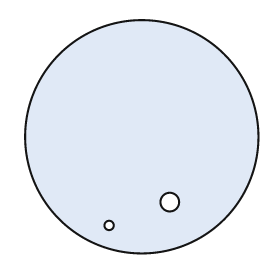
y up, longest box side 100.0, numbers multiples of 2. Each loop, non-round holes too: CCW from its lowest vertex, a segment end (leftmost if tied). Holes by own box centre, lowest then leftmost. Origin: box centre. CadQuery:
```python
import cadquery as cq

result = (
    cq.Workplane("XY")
    .moveTo(0.0, 0.0)
    .circle(50.0)
    .moveTo(-14.0, -38.0)
    .circle(2.0)
    .moveTo(12.0, -28.0)
    .circle(4.0)
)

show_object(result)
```